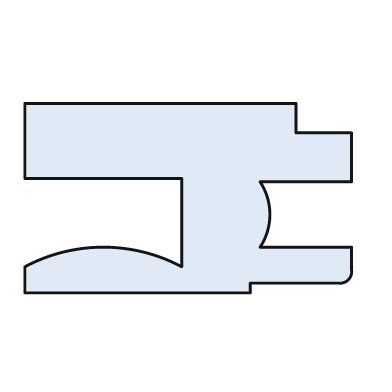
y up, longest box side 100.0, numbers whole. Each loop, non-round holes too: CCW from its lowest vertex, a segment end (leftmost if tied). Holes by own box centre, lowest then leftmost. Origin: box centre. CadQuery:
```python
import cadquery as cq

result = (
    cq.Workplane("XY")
    .moveTo(-50.0, -29.0)
    .lineTo(19.0, -29.0)
    .lineTo(19.0, -26.0)
    .lineTo(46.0, -26.0)
    .threePointArc((49.0, -25.0), (50.0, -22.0))
    .lineTo(50.0, -15.0)
    .lineTo(22.0, -15.0)
    .threePointArc((25.0, -5.0), (22.0, 5.0))
    .lineTo(50.0, 5.0)
    .lineTo(50.0, 20.0)
    .lineTo(33.0, 20.0)
    .lineTo(33.0, 29.0)
    .lineTo(-50.0, 29.0)
    .lineTo(-50.0, 6.0)
    .lineTo(-2.0, 6.0)
    .lineTo(-2.0, -21.0)
    .threePointArc((-26.0, -15.0), (-50.0, -21.0))
    .close()
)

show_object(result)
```